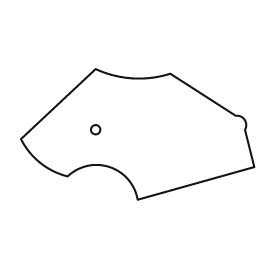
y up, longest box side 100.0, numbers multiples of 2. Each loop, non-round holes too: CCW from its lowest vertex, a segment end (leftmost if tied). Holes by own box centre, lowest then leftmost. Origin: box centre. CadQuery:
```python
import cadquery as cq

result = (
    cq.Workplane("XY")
    .moveTo(0.0, -28.0)
    .lineTo(50.0, -14.0)
    .lineTo(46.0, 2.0)
    .threePointArc((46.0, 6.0), (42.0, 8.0))
    .lineTo(14.0, 26.0)
    .threePointArc((-2.0, 24.0), (-18.0, 28.0))
    .lineTo(-50.0, -2.0)
    .threePointArc((-42.0, -12.0), (-30.0, -18.0))
    .threePointArc((-12.0, -14.0), (0.0, -28.0))
    .close()
    .moveTo(-18.0, 2.0)
    .circle(2.0)
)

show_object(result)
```